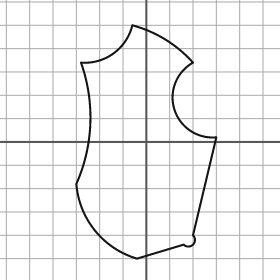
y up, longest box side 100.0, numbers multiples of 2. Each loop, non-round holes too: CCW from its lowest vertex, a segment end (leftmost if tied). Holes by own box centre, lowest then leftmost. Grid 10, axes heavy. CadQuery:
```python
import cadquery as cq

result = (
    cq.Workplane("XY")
    .moveTo(-4.0, -50.0)
    .lineTo(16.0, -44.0)
    .threePointArc((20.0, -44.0), (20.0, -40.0))
    .lineTo(30.0, 2.0)
    .threePointArc((12.0, 14.0), (20.0, 34.0))
    .threePointArc((8.0, 44.0), (-6.0, 50.0))
    .threePointArc((-14.0, 38.0), (-28.0, 34.0))
    .threePointArc((-24.0, 8.0), (-30.0, -18.0))
    .threePointArc((-22.0, -38.0), (-4.0, -50.0))
    .close()
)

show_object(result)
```